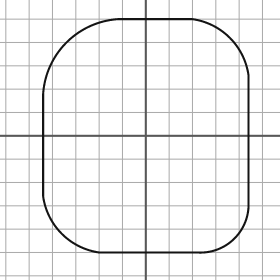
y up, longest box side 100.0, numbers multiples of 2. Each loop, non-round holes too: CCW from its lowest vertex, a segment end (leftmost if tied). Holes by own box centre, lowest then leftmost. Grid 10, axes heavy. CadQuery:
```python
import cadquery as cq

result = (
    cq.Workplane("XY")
    .moveTo(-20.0, -50.0)
    .lineTo(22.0, -50.0)
    .threePointArc((38.0, -44.0), (44.0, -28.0))
    .lineTo(44.0, 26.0)
    .threePointArc((36.0, 42.0), (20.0, 50.0))
    .lineTo(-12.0, 50.0)
    .threePointArc((-34.0, 40.0), (-44.0, 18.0))
    .lineTo(-44.0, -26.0)
    .threePointArc((-36.0, -42.0), (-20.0, -50.0))
    .close()
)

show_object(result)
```